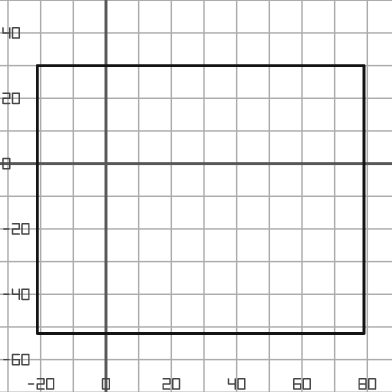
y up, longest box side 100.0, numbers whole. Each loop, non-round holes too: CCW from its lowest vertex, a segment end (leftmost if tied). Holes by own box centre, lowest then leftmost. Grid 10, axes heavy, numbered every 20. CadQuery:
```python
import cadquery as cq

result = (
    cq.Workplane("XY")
    .moveTo(-21.0, -52.0)
    .lineTo(79.0, -52.0)
    .lineTo(79.0, 30.0)
    .lineTo(-21.0, 30.0)
    .close()
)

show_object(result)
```